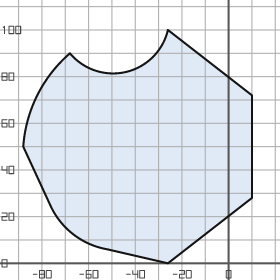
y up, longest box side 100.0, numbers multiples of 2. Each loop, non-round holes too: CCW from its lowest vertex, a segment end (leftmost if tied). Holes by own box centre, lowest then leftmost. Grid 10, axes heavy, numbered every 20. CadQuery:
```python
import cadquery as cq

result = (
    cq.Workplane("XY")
    .moveTo(-26.0, 0.0)
    .lineTo(10.0, 28.0)
    .lineTo(10.0, 72.0)
    .lineTo(-26.0, 100.0)
    .threePointArc((-44.0, 82.0), (-68.0, 90.0))
    .threePointArc((-82.0, 72.0), (-88.0, 50.0))
    .lineTo(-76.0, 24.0)
    .threePointArc((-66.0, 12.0), (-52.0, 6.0))
    .close()
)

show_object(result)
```